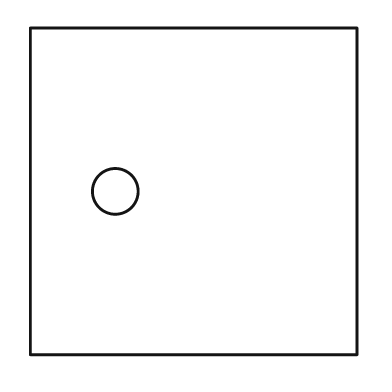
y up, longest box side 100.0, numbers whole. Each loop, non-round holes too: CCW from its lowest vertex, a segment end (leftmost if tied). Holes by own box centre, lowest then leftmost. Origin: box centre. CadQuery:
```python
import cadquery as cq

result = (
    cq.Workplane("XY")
    .moveTo(-50.0, -50.0)
    .lineTo(50.0, -50.0)
    .lineTo(50.0, 50.0)
    .lineTo(-50.0, 50.0)
    .close()
    .moveTo(-24.0, 0.0)
    .circle(7.0)
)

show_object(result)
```